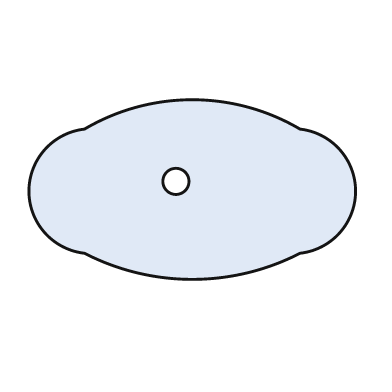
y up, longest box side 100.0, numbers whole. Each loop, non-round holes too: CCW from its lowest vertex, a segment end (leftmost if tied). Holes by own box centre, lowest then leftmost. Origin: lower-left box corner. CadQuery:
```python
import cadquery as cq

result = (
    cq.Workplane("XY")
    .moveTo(17.0, 8.0)
    .threePointArc((50.0, 0.0), (83.0, 8.0))
    .threePointArc((100.0, 27.0), (83.0, 46.0))
    .threePointArc((50.0, 55.0), (17.0, 46.0))
    .threePointArc((0.0, 27.0), (17.0, 8.0))
    .close()
    .moveTo(45.0, 30.0)
    .circle(4.0)
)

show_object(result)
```